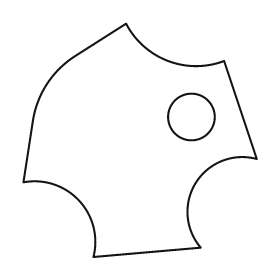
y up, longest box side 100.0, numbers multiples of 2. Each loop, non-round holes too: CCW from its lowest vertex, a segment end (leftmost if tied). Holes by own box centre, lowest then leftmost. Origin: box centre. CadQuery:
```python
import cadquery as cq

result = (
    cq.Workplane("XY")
    .moveTo(-20.0, -50.0)
    .lineTo(26.0, -46.0)
    .threePointArc((24.0, -18.0), (50.0, -8.0))
    .lineTo(36.0, 34.0)
    .threePointArc((12.0, 34.0), (-6.0, 50.0))
    .lineTo(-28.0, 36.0)
    .threePointArc((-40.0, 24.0), (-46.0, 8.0))
    .lineTo(-50.0, -18.0)
    .threePointArc((-26.0, -26.0), (-20.0, -50.0))
    .close()
    .moveTo(22.0, 10.0)
    .circle(10.0)
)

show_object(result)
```